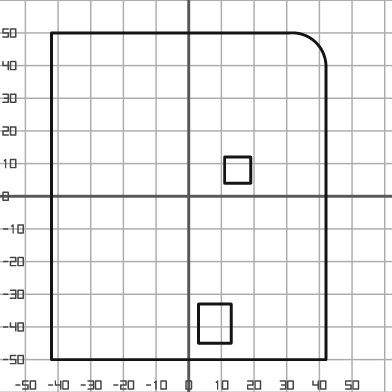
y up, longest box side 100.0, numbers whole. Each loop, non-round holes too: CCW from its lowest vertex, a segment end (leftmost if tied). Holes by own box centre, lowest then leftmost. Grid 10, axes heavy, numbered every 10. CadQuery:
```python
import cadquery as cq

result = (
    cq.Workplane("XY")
    .moveTo(-42.0, -50.0)
    .lineTo(42.0, -50.0)
    .lineTo(42.0, 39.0)
    .threePointArc((39.0, 47.0), (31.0, 50.0))
    .lineTo(-42.0, 50.0)
    .close()
    .moveTo(3.0, -45.0)
    .lineTo(13.0, -45.0)
    .lineTo(13.0, -33.0)
    .lineTo(3.0, -33.0)
    .close()
    .moveTo(11.0, 4.0)
    .lineTo(19.0, 4.0)
    .lineTo(19.0, 12.0)
    .lineTo(11.0, 12.0)
    .close()
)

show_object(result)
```